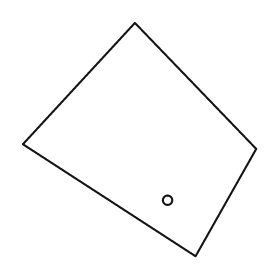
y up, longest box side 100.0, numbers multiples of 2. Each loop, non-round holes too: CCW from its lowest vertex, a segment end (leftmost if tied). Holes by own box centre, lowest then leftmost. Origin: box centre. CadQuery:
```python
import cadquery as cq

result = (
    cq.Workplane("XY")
    .moveTo(24.0, -50.0)
    .lineTo(50.0, -4.0)
    .lineTo(-2.0, 50.0)
    .lineTo(-50.0, -2.0)
    .close()
    .moveTo(12.0, -26.0)
    .circle(2.0)
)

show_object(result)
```